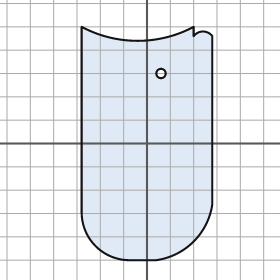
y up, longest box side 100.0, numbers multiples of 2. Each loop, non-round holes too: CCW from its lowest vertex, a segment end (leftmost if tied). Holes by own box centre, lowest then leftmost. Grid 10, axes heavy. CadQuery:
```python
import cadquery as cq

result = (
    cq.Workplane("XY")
    .moveTo(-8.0, -50.0)
    .lineTo(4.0, -50.0)
    .threePointArc((20.0, -42.0), (28.0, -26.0))
    .lineTo(28.0, 46.0)
    .threePointArc((24.0, 48.0), (20.0, 46.0))
    .lineTo(20.0, 50.0)
    .threePointArc((-4.0, 44.0), (-28.0, 50.0))
    .lineTo(-28.0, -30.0)
    .threePointArc((-22.0, -44.0), (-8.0, -50.0))
    .close()
    .moveTo(6.0, 30.0)
    .circle(2.0)
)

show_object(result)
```